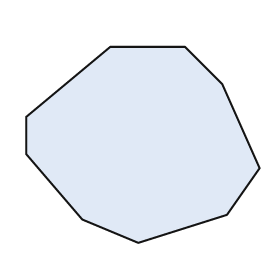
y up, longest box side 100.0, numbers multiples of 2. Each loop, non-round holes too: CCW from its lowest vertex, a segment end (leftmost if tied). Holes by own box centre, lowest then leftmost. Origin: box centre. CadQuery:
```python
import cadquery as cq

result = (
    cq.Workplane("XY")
    .moveTo(-2.0, -42.0)
    .lineTo(36.0, -30.0)
    .lineTo(50.0, -10.0)
    .lineTo(34.0, 26.0)
    .lineTo(18.0, 42.0)
    .lineTo(-14.0, 42.0)
    .lineTo(-50.0, 12.0)
    .lineTo(-50.0, -4.0)
    .lineTo(-26.0, -32.0)
    .close()
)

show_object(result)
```